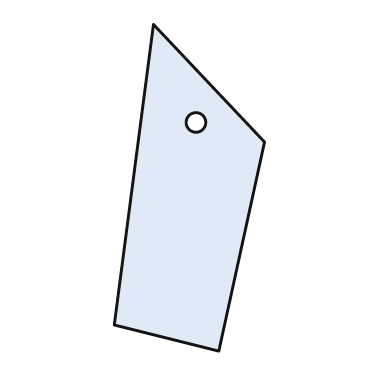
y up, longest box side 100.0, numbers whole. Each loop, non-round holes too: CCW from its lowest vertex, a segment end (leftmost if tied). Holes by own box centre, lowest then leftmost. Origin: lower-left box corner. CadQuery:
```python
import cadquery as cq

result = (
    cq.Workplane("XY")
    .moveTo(32.0, 0.0)
    .lineTo(46.0, 64.0)
    .lineTo(12.0, 100.0)
    .lineTo(0.0, 8.0)
    .close()
    .moveTo(25.0, 70.0)
    .circle(3.0)
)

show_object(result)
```